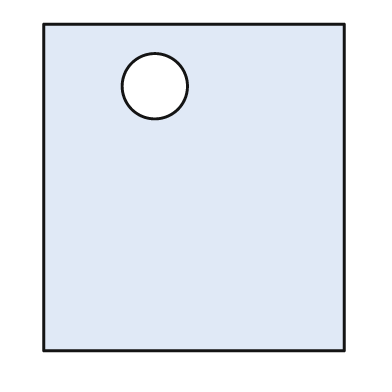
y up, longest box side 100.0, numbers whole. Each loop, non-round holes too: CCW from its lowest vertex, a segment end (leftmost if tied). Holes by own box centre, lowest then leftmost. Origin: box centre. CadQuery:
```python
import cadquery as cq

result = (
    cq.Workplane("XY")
    .moveTo(-46.0, -50.0)
    .lineTo(46.0, -50.0)
    .lineTo(46.0, 50.0)
    .lineTo(-46.0, 50.0)
    .close()
    .moveTo(-12.0, 31.0)
    .circle(10.0)
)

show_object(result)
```